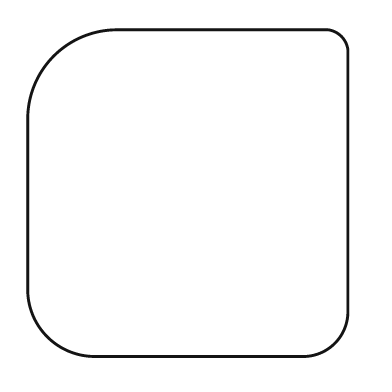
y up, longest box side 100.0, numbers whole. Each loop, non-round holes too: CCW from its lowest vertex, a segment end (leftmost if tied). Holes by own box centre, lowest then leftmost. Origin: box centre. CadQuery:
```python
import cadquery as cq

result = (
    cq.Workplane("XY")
    .moveTo(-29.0, -50.0)
    .lineTo(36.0, -50.0)
    .threePointArc((45.0, -46.0), (49.0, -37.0))
    .lineTo(49.0, 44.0)
    .threePointArc((47.0, 48.0), (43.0, 50.0))
    .lineTo(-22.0, 50.0)
    .threePointArc((-41.0, 42.0), (-49.0, 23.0))
    .lineTo(-49.0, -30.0)
    .threePointArc((-43.0, -44.0), (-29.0, -50.0))
    .close()
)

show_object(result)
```